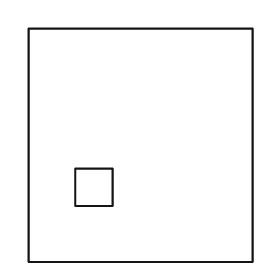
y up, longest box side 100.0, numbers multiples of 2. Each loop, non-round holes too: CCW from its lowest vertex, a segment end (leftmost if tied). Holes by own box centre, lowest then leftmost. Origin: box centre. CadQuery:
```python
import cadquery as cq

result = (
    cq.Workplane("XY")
    .moveTo(-48.0, -50.0)
    .lineTo(48.0, -50.0)
    .lineTo(48.0, 50.0)
    .lineTo(-48.0, 50.0)
    .close()
    .moveTo(-28.0, -26.0)
    .lineTo(-12.0, -26.0)
    .lineTo(-12.0, -10.0)
    .lineTo(-28.0, -10.0)
    .close()
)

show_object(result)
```